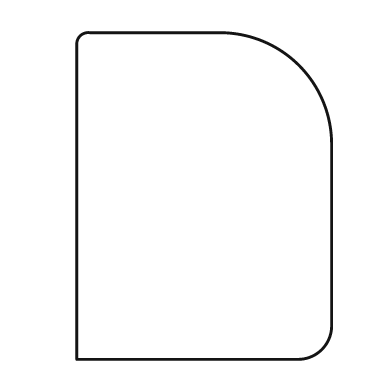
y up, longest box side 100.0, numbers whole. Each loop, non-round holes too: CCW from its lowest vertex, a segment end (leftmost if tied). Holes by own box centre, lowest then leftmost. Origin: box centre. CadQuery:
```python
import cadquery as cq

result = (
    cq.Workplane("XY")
    .moveTo(-39.0, -50.0)
    .lineTo(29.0, -50.0)
    .threePointArc((36.0, -47.0), (39.0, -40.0))
    .lineTo(39.0, 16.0)
    .threePointArc((29.0, 40.0), (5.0, 50.0))
    .lineTo(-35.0, 50.0)
    .threePointArc((-38.0, 49.0), (-39.0, 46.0))
    .close()
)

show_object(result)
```